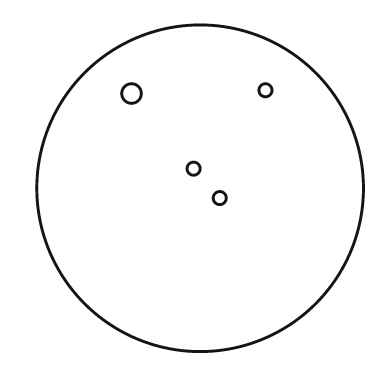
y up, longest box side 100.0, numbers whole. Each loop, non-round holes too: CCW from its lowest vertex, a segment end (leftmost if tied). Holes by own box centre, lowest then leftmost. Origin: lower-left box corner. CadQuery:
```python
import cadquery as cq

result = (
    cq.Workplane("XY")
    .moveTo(50.0, 50.0)
    .circle(50.0)
    .moveTo(56.0, 47.0)
    .circle(2.0)
    .moveTo(48.0, 56.0)
    .circle(2.0)
    .moveTo(29.0, 79.0)
    .circle(3.0)
    .moveTo(70.0, 80.0)
    .circle(2.0)
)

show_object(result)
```